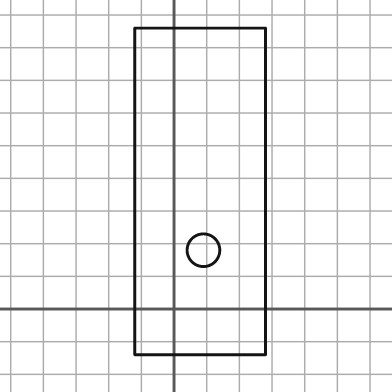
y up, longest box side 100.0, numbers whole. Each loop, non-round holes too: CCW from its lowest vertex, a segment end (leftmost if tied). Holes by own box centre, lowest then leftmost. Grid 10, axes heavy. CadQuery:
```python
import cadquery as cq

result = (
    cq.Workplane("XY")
    .moveTo(-12.0, -14.0)
    .lineTo(28.0, -14.0)
    .lineTo(28.0, 86.0)
    .lineTo(-12.0, 86.0)
    .close()
    .moveTo(9.0, 18.0)
    .circle(5.0)
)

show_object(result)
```